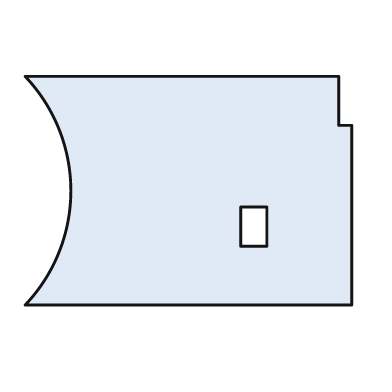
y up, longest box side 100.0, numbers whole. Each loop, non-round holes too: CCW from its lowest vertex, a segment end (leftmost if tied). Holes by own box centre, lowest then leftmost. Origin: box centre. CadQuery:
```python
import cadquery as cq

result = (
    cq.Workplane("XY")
    .moveTo(-50.0, -35.0)
    .lineTo(50.0, -35.0)
    .lineTo(50.0, 20.0)
    .lineTo(46.0, 20.0)
    .lineTo(46.0, 35.0)
    .lineTo(-50.0, 35.0)
    .threePointArc((-36.0, 0.0), (-50.0, -35.0))
    .close()
    .moveTo(16.0, -17.0)
    .lineTo(24.0, -17.0)
    .lineTo(24.0, -5.0)
    .lineTo(16.0, -5.0)
    .close()
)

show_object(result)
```